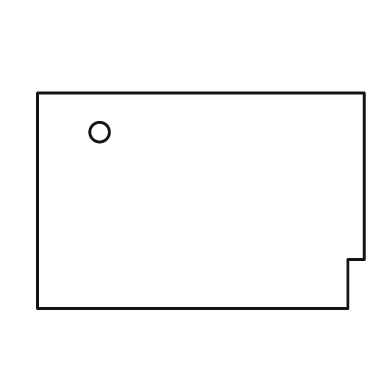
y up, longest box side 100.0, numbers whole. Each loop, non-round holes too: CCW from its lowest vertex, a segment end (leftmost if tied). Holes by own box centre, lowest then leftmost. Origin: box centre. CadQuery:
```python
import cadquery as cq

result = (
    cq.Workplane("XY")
    .moveTo(-50.0, -33.0)
    .lineTo(45.0, -33.0)
    .lineTo(45.0, -18.0)
    .lineTo(50.0, -18.0)
    .lineTo(50.0, 33.0)
    .lineTo(-50.0, 33.0)
    .close()
    .moveTo(-31.0, 21.0)
    .circle(3.0)
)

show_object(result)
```